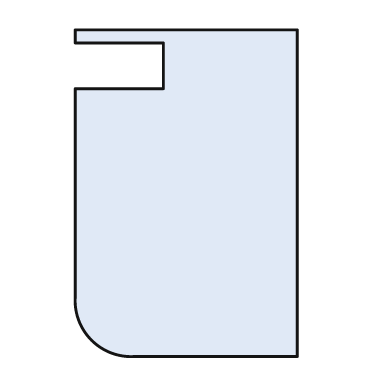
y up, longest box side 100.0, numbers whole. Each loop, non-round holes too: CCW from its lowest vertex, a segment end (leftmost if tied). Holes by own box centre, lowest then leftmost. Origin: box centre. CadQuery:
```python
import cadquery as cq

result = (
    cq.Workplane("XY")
    .moveTo(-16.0, -50.0)
    .lineTo(34.0, -50.0)
    .lineTo(34.0, 50.0)
    .lineTo(-34.0, 50.0)
    .lineTo(-34.0, 46.0)
    .lineTo(-7.0, 46.0)
    .lineTo(-7.0, 32.0)
    .lineTo(-34.0, 32.0)
    .lineTo(-34.0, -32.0)
    .threePointArc((-29.0, -45.0), (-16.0, -50.0))
    .close()
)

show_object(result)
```